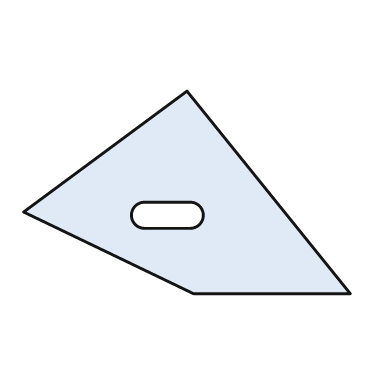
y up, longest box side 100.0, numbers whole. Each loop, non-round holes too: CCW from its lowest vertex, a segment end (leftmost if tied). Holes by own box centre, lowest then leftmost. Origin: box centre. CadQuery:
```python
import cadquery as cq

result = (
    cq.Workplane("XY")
    .moveTo(2.0, -31.0)
    .lineTo(50.0, -31.0)
    .lineTo(0.0, 31.0)
    .lineTo(-50.0, -6.0)
    .close()
    .moveTo(-13.0, -11.0)
    .lineTo(1.0, -11.0)
    .threePointArc((5.0, -7.0), (1.0, -3.0))
    .lineTo(-13.0, -3.0)
    .threePointArc((-17.0, -7.0), (-13.0, -11.0))
    .close()
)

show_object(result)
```